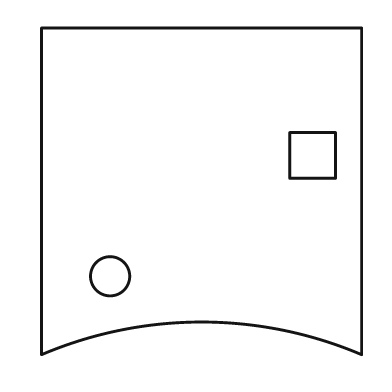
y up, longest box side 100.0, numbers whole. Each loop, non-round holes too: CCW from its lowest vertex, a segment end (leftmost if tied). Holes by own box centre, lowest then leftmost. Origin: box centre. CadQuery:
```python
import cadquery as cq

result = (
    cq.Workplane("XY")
    .moveTo(-49.0, -50.0)
    .threePointArc((0.0, -40.0), (49.0, -50.0))
    .lineTo(49.0, 50.0)
    .lineTo(-49.0, 50.0)
    .close()
    .moveTo(-28.0, -26.0)
    .circle(6.0)
    .moveTo(27.0, 4.0)
    .lineTo(41.0, 4.0)
    .lineTo(41.0, 18.0)
    .lineTo(27.0, 18.0)
    .close()
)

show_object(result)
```